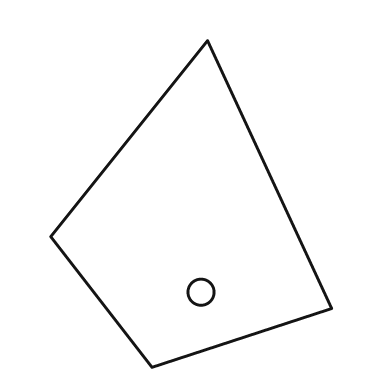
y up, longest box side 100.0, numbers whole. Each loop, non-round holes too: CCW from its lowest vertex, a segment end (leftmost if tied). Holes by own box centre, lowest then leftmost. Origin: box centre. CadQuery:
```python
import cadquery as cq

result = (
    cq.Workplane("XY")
    .moveTo(-12.0, -50.0)
    .lineTo(43.0, -32.0)
    .lineTo(5.0, 50.0)
    .lineTo(-43.0, -10.0)
    .close()
    .moveTo(3.0, -27.0)
    .circle(4.0)
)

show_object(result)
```